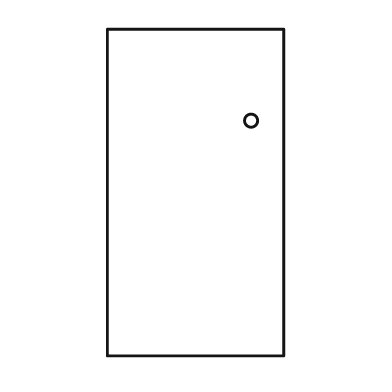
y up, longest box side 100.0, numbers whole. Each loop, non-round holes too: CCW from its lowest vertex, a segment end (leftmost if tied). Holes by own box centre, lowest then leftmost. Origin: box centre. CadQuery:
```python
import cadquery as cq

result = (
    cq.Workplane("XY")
    .moveTo(-27.0, -50.0)
    .lineTo(27.0, -50.0)
    .lineTo(27.0, 50.0)
    .lineTo(-27.0, 50.0)
    .close()
    .moveTo(17.0, 22.0)
    .circle(2.0)
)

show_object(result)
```